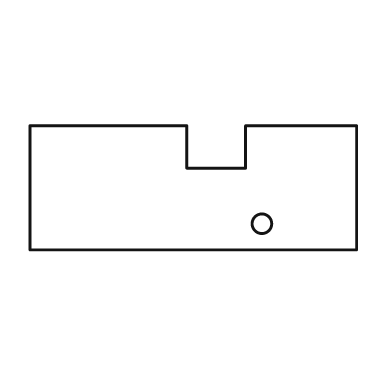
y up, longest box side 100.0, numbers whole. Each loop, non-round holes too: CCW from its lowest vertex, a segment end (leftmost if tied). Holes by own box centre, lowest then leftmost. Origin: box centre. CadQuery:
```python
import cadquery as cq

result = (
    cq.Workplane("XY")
    .moveTo(-50.0, -19.0)
    .lineTo(50.0, -19.0)
    .lineTo(50.0, 19.0)
    .lineTo(16.0, 19.0)
    .lineTo(16.0, 6.0)
    .lineTo(-2.0, 6.0)
    .lineTo(-2.0, 19.0)
    .lineTo(-50.0, 19.0)
    .close()
    .moveTo(21.0, -11.0)
    .circle(3.0)
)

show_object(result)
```